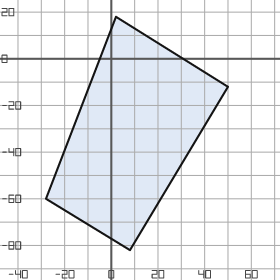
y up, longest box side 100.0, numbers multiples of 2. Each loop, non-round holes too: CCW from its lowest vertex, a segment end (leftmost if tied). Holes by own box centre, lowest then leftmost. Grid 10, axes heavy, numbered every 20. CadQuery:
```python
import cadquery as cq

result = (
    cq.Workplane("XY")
    .moveTo(8.0, -82.0)
    .lineTo(50.0, -12.0)
    .lineTo(2.0, 18.0)
    .lineTo(-28.0, -60.0)
    .close()
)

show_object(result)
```